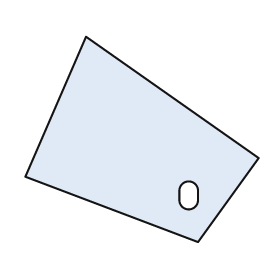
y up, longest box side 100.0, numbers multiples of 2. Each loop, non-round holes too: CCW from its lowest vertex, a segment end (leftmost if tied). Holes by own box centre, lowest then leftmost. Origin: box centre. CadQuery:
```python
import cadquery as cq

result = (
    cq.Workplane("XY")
    .moveTo(24.0, -44.0)
    .lineTo(50.0, -8.0)
    .lineTo(-24.0, 44.0)
    .lineTo(-50.0, -16.0)
    .close()
    .moveTo(16.0, -26.0)
    .threePointArc((20.0, -30.0), (24.0, -26.0))
    .lineTo(24.0, -22.0)
    .threePointArc((20.0, -18.0), (16.0, -22.0))
    .close()
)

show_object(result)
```